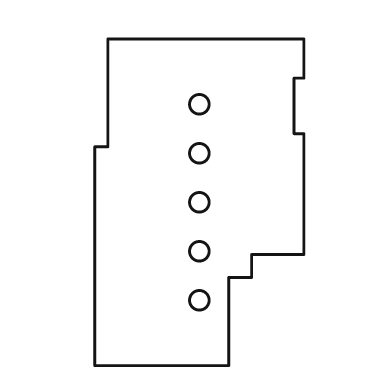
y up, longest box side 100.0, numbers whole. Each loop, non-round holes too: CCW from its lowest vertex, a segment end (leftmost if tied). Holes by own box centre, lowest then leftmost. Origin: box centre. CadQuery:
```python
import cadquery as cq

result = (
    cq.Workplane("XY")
    .moveTo(-32.0, -50.0)
    .lineTo(9.0, -50.0)
    .lineTo(9.0, -23.0)
    .lineTo(16.0, -23.0)
    .lineTo(16.0, -16.0)
    .lineTo(32.0, -16.0)
    .lineTo(32.0, 21.0)
    .lineTo(29.0, 21.0)
    .lineTo(29.0, 38.0)
    .lineTo(32.0, 38.0)
    .lineTo(32.0, 50.0)
    .lineTo(-28.0, 50.0)
    .lineTo(-28.0, 17.0)
    .lineTo(-32.0, 17.0)
    .close()
    .moveTo(0.0, -30.0)
    .circle(3.0)
    .moveTo(0.0, -15.0)
    .circle(3.0)
    .moveTo(0.0, 0.0)
    .circle(3.0)
    .moveTo(0.0, 15.0)
    .circle(3.0)
    .moveTo(0.0, 30.0)
    .circle(3.0)
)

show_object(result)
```